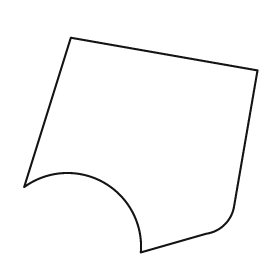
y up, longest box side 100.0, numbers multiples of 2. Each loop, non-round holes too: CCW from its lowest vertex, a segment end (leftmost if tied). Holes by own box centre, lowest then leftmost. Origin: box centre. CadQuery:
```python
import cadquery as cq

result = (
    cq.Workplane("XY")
    .moveTo(0.0, -46.0)
    .lineTo(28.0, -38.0)
    .threePointArc((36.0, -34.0), (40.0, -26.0))
    .lineTo(50.0, 32.0)
    .lineTo(-30.0, 46.0)
    .lineTo(-50.0, -18.0)
    .threePointArc((-16.0, -16.0), (0.0, -46.0))
    .close()
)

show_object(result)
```